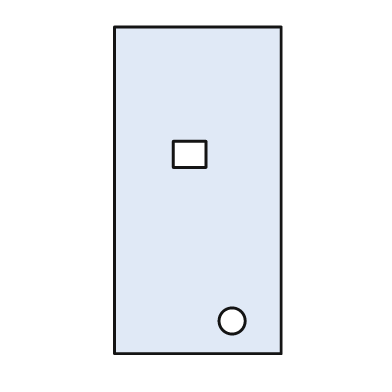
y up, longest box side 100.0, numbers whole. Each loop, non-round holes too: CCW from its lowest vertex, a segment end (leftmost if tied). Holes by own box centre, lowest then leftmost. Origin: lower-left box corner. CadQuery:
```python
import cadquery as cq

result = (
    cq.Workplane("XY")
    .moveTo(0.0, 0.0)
    .lineTo(51.0, 0.0)
    .lineTo(51.0, 100.0)
    .lineTo(0.0, 100.0)
    .close()
    .moveTo(36.0, 10.0)
    .circle(4.0)
    .moveTo(18.0, 57.0)
    .lineTo(28.0, 57.0)
    .lineTo(28.0, 65.0)
    .lineTo(18.0, 65.0)
    .close()
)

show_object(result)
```